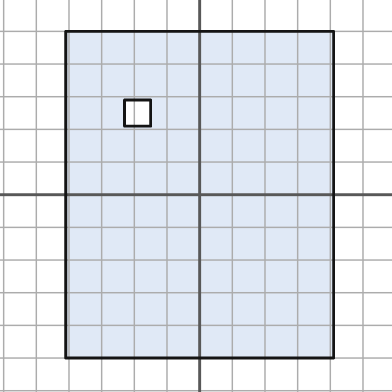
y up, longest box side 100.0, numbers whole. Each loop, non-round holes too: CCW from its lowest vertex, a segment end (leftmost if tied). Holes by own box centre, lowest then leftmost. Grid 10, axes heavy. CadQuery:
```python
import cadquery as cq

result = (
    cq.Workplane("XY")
    .moveTo(-41.0, -50.0)
    .lineTo(41.0, -50.0)
    .lineTo(41.0, 50.0)
    .lineTo(-41.0, 50.0)
    .close()
    .moveTo(-23.0, 21.0)
    .lineTo(-15.0, 21.0)
    .lineTo(-15.0, 29.0)
    .lineTo(-23.0, 29.0)
    .close()
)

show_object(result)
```